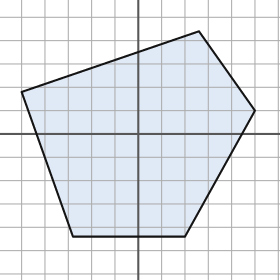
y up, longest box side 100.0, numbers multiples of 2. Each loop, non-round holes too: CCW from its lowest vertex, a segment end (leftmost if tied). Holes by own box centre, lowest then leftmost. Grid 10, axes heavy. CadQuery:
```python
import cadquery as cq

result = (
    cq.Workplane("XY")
    .moveTo(-28.0, -44.0)
    .lineTo(20.0, -44.0)
    .lineTo(50.0, 10.0)
    .lineTo(26.0, 44.0)
    .lineTo(-50.0, 18.0)
    .close()
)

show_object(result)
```